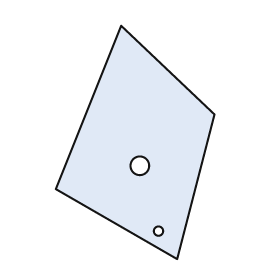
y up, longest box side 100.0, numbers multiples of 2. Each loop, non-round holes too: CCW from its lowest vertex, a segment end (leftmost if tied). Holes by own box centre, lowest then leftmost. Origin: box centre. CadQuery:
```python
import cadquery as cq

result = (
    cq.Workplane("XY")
    .moveTo(18.0, -50.0)
    .lineTo(34.0, 12.0)
    .lineTo(-6.0, 50.0)
    .lineTo(-34.0, -20.0)
    .close()
    .moveTo(10.0, -38.0)
    .circle(2.0)
    .moveTo(2.0, -10.0)
    .circle(4.0)
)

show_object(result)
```